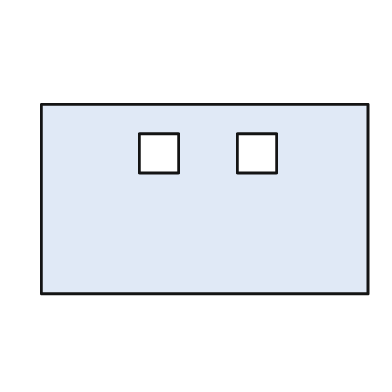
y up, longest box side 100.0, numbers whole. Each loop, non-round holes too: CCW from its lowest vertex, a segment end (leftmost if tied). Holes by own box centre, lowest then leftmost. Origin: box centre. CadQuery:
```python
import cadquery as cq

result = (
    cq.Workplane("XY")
    .moveTo(-50.0, -29.0)
    .lineTo(50.0, -29.0)
    .lineTo(50.0, 29.0)
    .lineTo(-50.0, 29.0)
    .close()
    .moveTo(-20.0, 8.0)
    .lineTo(-8.0, 8.0)
    .lineTo(-8.0, 20.0)
    .lineTo(-20.0, 20.0)
    .close()
    .moveTo(10.0, 8.0)
    .lineTo(22.0, 8.0)
    .lineTo(22.0, 20.0)
    .lineTo(10.0, 20.0)
    .close()
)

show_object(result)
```